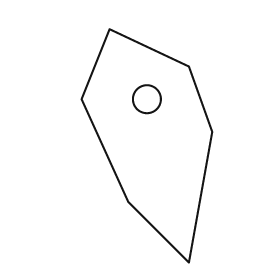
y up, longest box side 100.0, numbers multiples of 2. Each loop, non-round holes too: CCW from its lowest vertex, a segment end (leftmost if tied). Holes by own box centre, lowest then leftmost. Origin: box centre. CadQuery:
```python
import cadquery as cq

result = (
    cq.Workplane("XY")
    .moveTo(18.0, -50.0)
    .lineTo(28.0, 6.0)
    .lineTo(18.0, 34.0)
    .lineTo(-16.0, 50.0)
    .lineTo(-28.0, 20.0)
    .lineTo(-8.0, -24.0)
    .close()
    .moveTo(0.0, 20.0)
    .circle(6.0)
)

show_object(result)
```